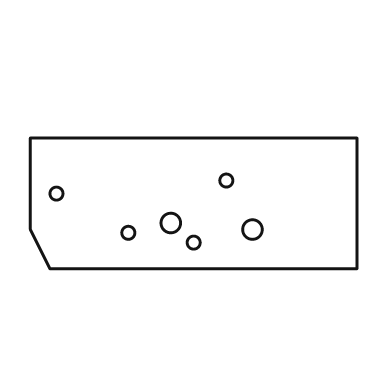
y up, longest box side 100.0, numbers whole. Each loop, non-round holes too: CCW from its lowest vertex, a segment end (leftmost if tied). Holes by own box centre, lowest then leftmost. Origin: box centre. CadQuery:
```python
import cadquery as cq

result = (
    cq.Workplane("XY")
    .moveTo(-44.0, -20.0)
    .lineTo(50.0, -20.0)
    .lineTo(50.0, 20.0)
    .lineTo(-50.0, 20.0)
    .lineTo(-50.0, -8.0)
    .close()
    .moveTo(0.0, -12.0)
    .circle(2.0)
    .moveTo(-20.0, -9.0)
    .circle(2.0)
    .moveTo(18.0, -8.0)
    .circle(3.0)
    .moveTo(-7.0, -6.0)
    .circle(3.0)
    .moveTo(-42.0, 3.0)
    .circle(2.0)
    .moveTo(10.0, 7.0)
    .circle(2.0)
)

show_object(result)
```